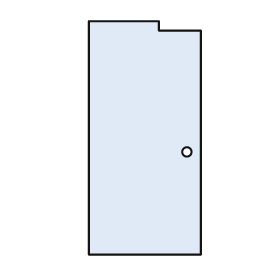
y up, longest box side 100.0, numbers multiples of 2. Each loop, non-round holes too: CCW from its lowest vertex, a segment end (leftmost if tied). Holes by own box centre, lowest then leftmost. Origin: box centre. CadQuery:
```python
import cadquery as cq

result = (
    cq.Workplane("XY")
    .moveTo(-24.0, -50.0)
    .lineTo(24.0, -50.0)
    .lineTo(24.0, 46.0)
    .lineTo(6.0, 46.0)
    .lineTo(6.0, 50.0)
    .lineTo(-24.0, 50.0)
    .close()
    .moveTo(18.0, -6.0)
    .circle(2.0)
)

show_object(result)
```